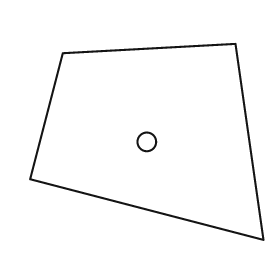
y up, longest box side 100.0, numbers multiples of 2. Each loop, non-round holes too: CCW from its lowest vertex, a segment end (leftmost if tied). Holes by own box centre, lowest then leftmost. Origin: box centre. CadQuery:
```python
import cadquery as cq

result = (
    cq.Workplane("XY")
    .moveTo(50.0, -42.0)
    .lineTo(38.0, 42.0)
    .lineTo(-36.0, 38.0)
    .lineTo(-50.0, -16.0)
    .close()
    .moveTo(0.0, 0.0)
    .circle(4.0)
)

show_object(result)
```